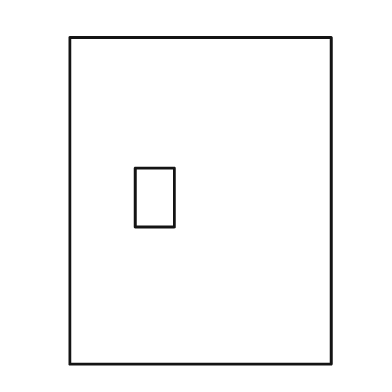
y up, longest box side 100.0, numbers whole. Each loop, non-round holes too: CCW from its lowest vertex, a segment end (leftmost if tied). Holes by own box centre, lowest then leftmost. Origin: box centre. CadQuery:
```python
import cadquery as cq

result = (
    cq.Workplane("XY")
    .moveTo(-40.0, -50.0)
    .lineTo(40.0, -50.0)
    .lineTo(40.0, 50.0)
    .lineTo(-40.0, 50.0)
    .close()
    .moveTo(-20.0, -8.0)
    .lineTo(-8.0, -8.0)
    .lineTo(-8.0, 10.0)
    .lineTo(-20.0, 10.0)
    .close()
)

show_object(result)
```